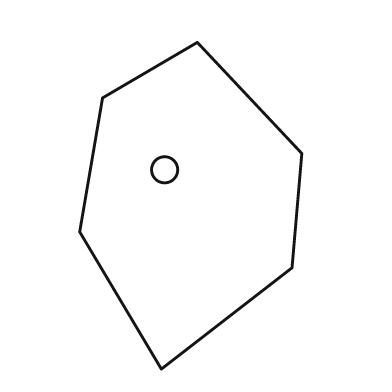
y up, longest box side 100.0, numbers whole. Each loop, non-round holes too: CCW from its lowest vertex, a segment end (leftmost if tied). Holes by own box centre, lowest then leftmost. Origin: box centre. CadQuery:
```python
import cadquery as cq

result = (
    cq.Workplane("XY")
    .moveTo(-9.0, -50.0)
    .lineTo(31.0, -19.0)
    .lineTo(34.0, 16.0)
    .lineTo(2.0, 50.0)
    .lineTo(-27.0, 33.0)
    .lineTo(-34.0, -8.0)
    .close()
    .moveTo(-8.0, 11.0)
    .circle(4.0)
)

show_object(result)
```